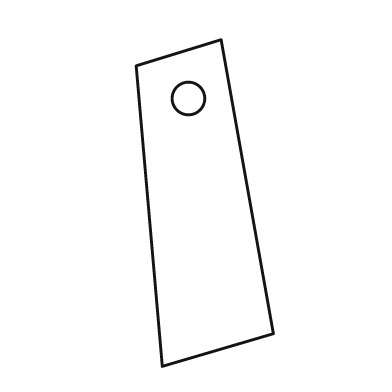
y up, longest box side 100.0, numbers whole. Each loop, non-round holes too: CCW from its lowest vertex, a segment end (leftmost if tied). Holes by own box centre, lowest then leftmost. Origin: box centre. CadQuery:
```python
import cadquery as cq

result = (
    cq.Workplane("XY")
    .moveTo(-13.0, -50.0)
    .lineTo(21.0, -40.0)
    .lineTo(5.0, 50.0)
    .lineTo(-21.0, 42.0)
    .close()
    .moveTo(-5.0, 32.0)
    .circle(5.0)
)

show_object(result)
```